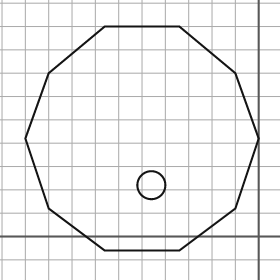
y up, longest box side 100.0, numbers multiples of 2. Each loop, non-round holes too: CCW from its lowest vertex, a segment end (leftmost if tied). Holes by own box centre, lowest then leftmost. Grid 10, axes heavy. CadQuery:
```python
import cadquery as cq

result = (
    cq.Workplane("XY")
    .moveTo(-66.0, -6.0)
    .lineTo(-34.0, -6.0)
    .lineTo(-10.0, 12.0)
    .lineTo(0.0, 42.0)
    .lineTo(-10.0, 70.0)
    .lineTo(-34.0, 90.0)
    .lineTo(-66.0, 90.0)
    .lineTo(-90.0, 70.0)
    .lineTo(-100.0, 42.0)
    .lineTo(-90.0, 12.0)
    .close()
    .moveTo(-46.0, 22.0)
    .circle(6.0)
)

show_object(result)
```